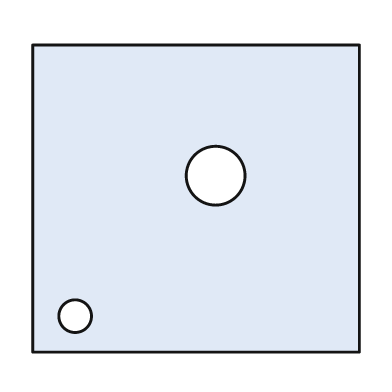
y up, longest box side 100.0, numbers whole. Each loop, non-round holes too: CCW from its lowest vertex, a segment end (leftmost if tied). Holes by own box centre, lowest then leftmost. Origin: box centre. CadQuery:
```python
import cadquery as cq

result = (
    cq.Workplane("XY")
    .moveTo(-50.0, -47.0)
    .lineTo(50.0, -47.0)
    .lineTo(50.0, 47.0)
    .lineTo(-50.0, 47.0)
    .close()
    .moveTo(-37.0, -36.0)
    .circle(5.0)
    .moveTo(6.0, 7.0)
    .circle(9.0)
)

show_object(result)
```